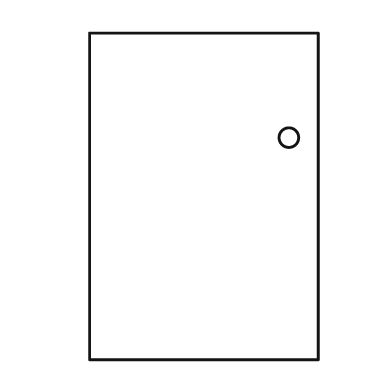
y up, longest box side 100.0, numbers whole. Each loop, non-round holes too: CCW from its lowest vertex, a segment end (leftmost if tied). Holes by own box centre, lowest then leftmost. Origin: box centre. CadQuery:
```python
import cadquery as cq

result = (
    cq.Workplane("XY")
    .moveTo(-35.0, -50.0)
    .lineTo(35.0, -50.0)
    .lineTo(35.0, 50.0)
    .lineTo(-35.0, 50.0)
    .close()
    .moveTo(26.0, 18.0)
    .circle(3.0)
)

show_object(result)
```